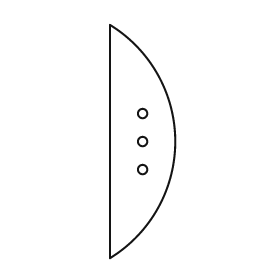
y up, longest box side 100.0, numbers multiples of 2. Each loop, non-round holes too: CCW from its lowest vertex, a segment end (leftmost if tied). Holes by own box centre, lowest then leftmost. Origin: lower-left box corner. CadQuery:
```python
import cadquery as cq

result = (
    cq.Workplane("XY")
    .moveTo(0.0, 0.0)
    .threePointArc((28.0, 50.0), (0.0, 100.0))
    .close()
    .moveTo(14.0, 38.0)
    .circle(2.0)
    .moveTo(14.0, 50.0)
    .circle(2.0)
    .moveTo(14.0, 62.0)
    .circle(2.0)
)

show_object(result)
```